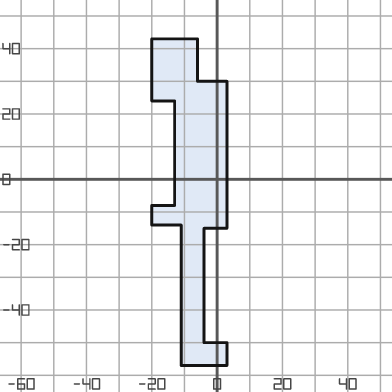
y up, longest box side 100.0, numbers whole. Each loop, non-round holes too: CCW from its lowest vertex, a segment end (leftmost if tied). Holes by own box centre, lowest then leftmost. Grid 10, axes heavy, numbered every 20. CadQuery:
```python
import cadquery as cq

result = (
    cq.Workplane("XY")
    .moveTo(-11.0, -57.0)
    .lineTo(3.0, -57.0)
    .lineTo(3.0, -50.0)
    .lineTo(-4.0, -50.0)
    .lineTo(-4.0, -15.0)
    .lineTo(3.0, -15.0)
    .lineTo(3.0, 30.0)
    .lineTo(-6.0, 30.0)
    .lineTo(-6.0, 43.0)
    .lineTo(-20.0, 43.0)
    .lineTo(-20.0, 24.0)
    .lineTo(-13.0, 24.0)
    .lineTo(-13.0, -8.0)
    .lineTo(-20.0, -8.0)
    .lineTo(-20.0, -14.0)
    .lineTo(-11.0, -14.0)
    .close()
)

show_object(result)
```